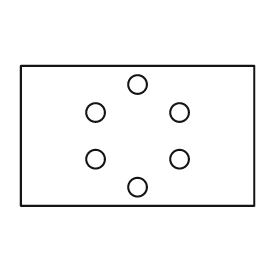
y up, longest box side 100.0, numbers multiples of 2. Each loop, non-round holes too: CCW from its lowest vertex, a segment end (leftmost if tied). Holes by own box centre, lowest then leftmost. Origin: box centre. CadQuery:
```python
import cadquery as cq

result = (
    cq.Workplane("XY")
    .moveTo(-50.0, -30.0)
    .lineTo(50.0, -30.0)
    .lineTo(50.0, 30.0)
    .lineTo(-50.0, 30.0)
    .close()
    .moveTo(0.0, -22.0)
    .circle(4.0)
    .moveTo(-18.0, -10.0)
    .circle(4.0)
    .moveTo(18.0, -10.0)
    .circle(4.0)
    .moveTo(-18.0, 10.0)
    .circle(4.0)
    .moveTo(18.0, 10.0)
    .circle(4.0)
    .moveTo(0.0, 22.0)
    .circle(4.0)
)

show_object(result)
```